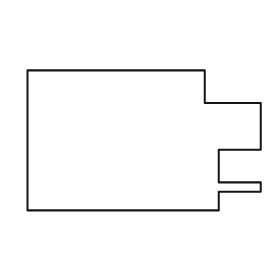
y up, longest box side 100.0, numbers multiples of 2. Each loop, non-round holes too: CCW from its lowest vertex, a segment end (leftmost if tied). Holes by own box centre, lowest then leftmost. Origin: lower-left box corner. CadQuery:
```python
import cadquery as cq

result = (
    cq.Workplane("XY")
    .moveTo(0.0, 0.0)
    .lineTo(82.0, 0.0)
    .lineTo(82.0, 8.0)
    .lineTo(100.0, 8.0)
    .lineTo(100.0, 12.0)
    .lineTo(82.0, 12.0)
    .lineTo(82.0, 26.0)
    .lineTo(100.0, 26.0)
    .lineTo(100.0, 46.0)
    .lineTo(76.0, 46.0)
    .lineTo(76.0, 60.0)
    .lineTo(0.0, 60.0)
    .close()
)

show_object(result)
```